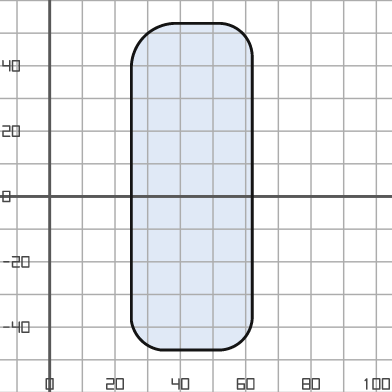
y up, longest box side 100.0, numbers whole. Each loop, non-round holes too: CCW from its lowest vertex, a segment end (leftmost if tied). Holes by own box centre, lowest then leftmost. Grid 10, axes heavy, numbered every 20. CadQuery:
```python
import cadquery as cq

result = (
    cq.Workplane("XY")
    .moveTo(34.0, -47.0)
    .lineTo(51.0, -47.0)
    .threePointArc((59.0, -44.0), (62.0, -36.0))
    .lineTo(62.0, 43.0)
    .threePointArc((59.0, 50.0), (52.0, 53.0))
    .lineTo(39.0, 53.0)
    .threePointArc((29.0, 49.0), (25.0, 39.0))
    .lineTo(25.0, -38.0)
    .threePointArc((28.0, -44.0), (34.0, -47.0))
    .close()
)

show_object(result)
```